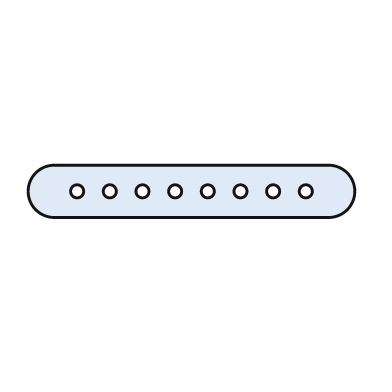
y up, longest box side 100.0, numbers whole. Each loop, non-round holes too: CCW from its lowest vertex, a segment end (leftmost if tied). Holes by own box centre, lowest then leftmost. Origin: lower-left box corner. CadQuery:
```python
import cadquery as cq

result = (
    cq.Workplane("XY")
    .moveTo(8.0, 0.0)
    .lineTo(92.0, 0.0)
    .threePointArc((100.0, 8.0), (92.0, 16.0))
    .lineTo(8.0, 16.0)
    .threePointArc((0.0, 8.0), (8.0, 0.0))
    .close()
    .moveTo(15.0, 8.0)
    .circle(2.0)
    .moveTo(25.0, 8.0)
    .circle(2.0)
    .moveTo(35.0, 8.0)
    .circle(2.0)
    .moveTo(45.0, 8.0)
    .circle(2.0)
    .moveTo(55.0, 8.0)
    .circle(2.0)
    .moveTo(65.0, 8.0)
    .circle(2.0)
    .moveTo(75.0, 8.0)
    .circle(2.0)
    .moveTo(85.0, 8.0)
    .circle(2.0)
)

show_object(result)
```